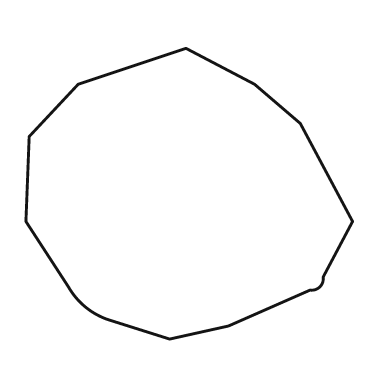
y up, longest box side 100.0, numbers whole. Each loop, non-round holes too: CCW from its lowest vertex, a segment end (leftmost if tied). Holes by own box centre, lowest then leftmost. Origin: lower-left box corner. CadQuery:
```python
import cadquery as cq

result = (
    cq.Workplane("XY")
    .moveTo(44.0, 0.0)
    .lineTo(62.0, 4.0)
    .lineTo(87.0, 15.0)
    .threePointArc((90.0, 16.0), (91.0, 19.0))
    .lineTo(100.0, 36.0)
    .lineTo(84.0, 66.0)
    .lineTo(70.0, 78.0)
    .lineTo(49.0, 89.0)
    .lineTo(16.0, 78.0)
    .lineTo(1.0, 62.0)
    .lineTo(0.0, 36.0)
    .lineTo(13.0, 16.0)
    .threePointArc((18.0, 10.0), (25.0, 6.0))
    .close()
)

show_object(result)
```